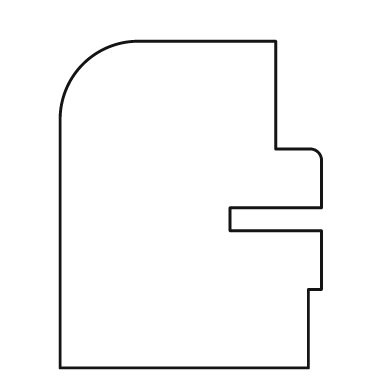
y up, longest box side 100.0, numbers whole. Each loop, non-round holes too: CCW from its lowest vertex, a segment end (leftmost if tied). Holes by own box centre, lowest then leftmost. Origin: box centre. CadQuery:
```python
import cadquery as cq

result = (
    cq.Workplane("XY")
    .moveTo(-40.0, -50.0)
    .lineTo(36.0, -50.0)
    .lineTo(36.0, -26.0)
    .lineTo(40.0, -26.0)
    .lineTo(40.0, -8.0)
    .lineTo(12.0, -8.0)
    .lineTo(12.0, -1.0)
    .lineTo(40.0, -1.0)
    .lineTo(40.0, 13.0)
    .threePointArc((39.0, 16.0), (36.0, 17.0))
    .lineTo(26.0, 17.0)
    .lineTo(26.0, 50.0)
    .lineTo(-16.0, 50.0)
    .threePointArc((-33.0, 43.0), (-40.0, 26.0))
    .close()
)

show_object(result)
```